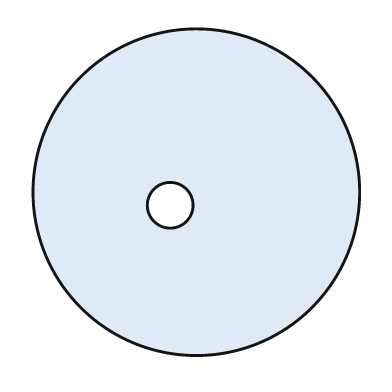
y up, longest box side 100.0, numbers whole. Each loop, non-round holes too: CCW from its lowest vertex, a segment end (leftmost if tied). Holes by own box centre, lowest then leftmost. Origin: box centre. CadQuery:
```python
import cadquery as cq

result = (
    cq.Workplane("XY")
    .moveTo(0.0, 0.0)
    .circle(50.0)
    .moveTo(-8.0, -4.0)
    .circle(7.0)
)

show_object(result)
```